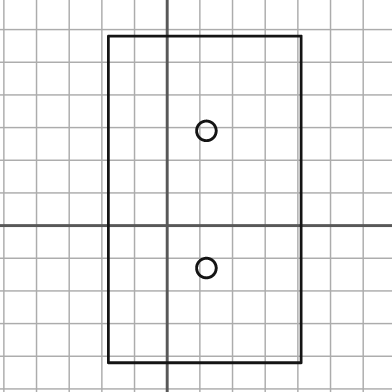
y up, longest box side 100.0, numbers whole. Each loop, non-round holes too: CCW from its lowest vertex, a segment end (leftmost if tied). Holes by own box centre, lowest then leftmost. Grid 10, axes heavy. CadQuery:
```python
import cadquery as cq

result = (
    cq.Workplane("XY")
    .moveTo(-18.0, -42.0)
    .lineTo(41.0, -42.0)
    .lineTo(41.0, 58.0)
    .lineTo(-18.0, 58.0)
    .close()
    .moveTo(12.0, -13.0)
    .circle(3.0)
    .moveTo(12.0, 29.0)
    .circle(3.0)
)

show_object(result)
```